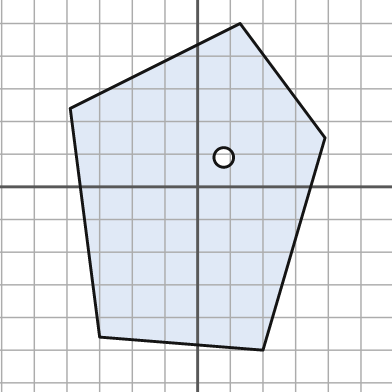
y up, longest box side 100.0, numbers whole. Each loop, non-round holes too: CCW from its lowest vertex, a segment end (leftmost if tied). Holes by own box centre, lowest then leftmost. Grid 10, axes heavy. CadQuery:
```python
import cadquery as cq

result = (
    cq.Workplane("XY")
    .moveTo(20.0, -50.0)
    .lineTo(39.0, 15.0)
    .lineTo(13.0, 50.0)
    .lineTo(-39.0, 24.0)
    .lineTo(-30.0, -46.0)
    .close()
    .moveTo(8.0, 9.0)
    .circle(3.0)
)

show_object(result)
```